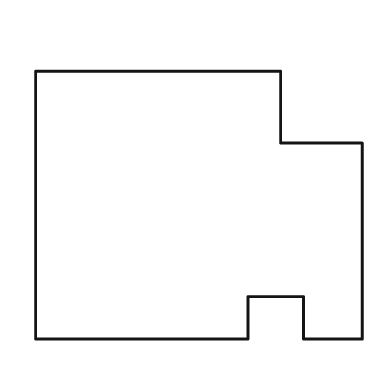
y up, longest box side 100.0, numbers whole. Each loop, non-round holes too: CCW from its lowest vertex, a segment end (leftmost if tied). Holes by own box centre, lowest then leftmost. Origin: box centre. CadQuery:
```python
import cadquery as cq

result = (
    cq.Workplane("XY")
    .moveTo(-50.0, -41.0)
    .lineTo(15.0, -41.0)
    .lineTo(15.0, -28.0)
    .lineTo(32.0, -28.0)
    .lineTo(32.0, -41.0)
    .lineTo(50.0, -41.0)
    .lineTo(50.0, 19.0)
    .lineTo(25.0, 19.0)
    .lineTo(25.0, 41.0)
    .lineTo(-50.0, 41.0)
    .close()
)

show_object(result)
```